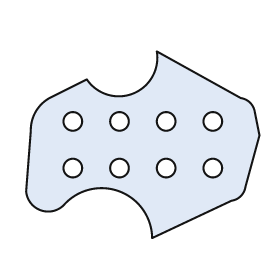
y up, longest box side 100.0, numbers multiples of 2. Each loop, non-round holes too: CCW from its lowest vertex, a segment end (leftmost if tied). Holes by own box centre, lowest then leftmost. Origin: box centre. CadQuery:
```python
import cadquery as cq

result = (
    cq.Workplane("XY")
    .moveTo(4.0, -40.0)
    .lineTo(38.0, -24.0)
    .threePointArc((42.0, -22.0), (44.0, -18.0))
    .lineTo(50.0, 4.0)
    .lineTo(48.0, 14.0)
    .threePointArc((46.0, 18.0), (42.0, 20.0))
    .lineTo(6.0, 40.0)
    .threePointArc((-4.0, 22.0), (-24.0, 28.0))
    .lineTo(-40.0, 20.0)
    .threePointArc((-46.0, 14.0), (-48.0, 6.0))
    .lineTo(-50.0, -20.0)
    .threePointArc((-44.0, -28.0), (-34.0, -26.0))
    .threePointArc((-10.0, -20.0), (4.0, -40.0))
    .close()
    .moveTo(-30.0, -10.0)
    .circle(4.0)
    .moveTo(-10.0, -10.0)
    .circle(4.0)
    .moveTo(10.0, -10.0)
    .circle(4.0)
    .moveTo(30.0, -10.0)
    .circle(4.0)
    .moveTo(-30.0, 10.0)
    .circle(4.0)
    .moveTo(-10.0, 10.0)
    .circle(4.0)
    .moveTo(10.0, 10.0)
    .circle(4.0)
    .moveTo(30.0, 10.0)
    .circle(4.0)
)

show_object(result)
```